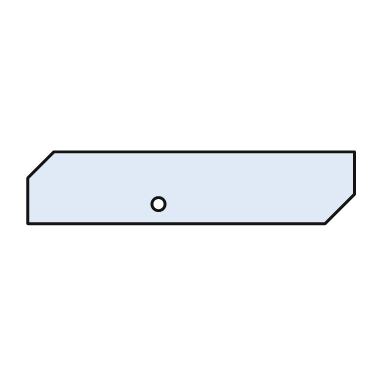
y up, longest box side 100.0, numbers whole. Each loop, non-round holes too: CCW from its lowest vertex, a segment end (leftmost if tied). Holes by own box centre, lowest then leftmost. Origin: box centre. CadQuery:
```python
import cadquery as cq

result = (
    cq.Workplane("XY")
    .moveTo(-50.0, -11.0)
    .lineTo(41.0, -11.0)
    .lineTo(50.0, -2.0)
    .lineTo(50.0, 11.0)
    .lineTo(-42.0, 11.0)
    .lineTo(-50.0, 3.0)
    .close()
    .moveTo(-10.0, -5.0)
    .circle(2.0)
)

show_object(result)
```